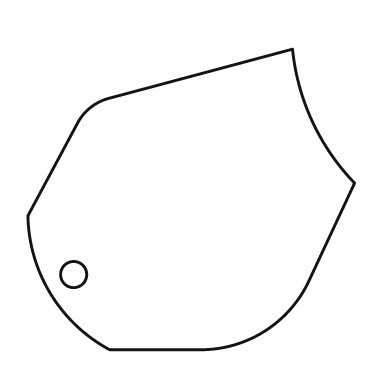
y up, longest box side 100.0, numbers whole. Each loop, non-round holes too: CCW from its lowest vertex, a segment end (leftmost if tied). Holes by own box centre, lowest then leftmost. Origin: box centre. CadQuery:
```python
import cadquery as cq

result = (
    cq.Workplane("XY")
    .moveTo(-25.0, -46.0)
    .lineTo(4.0, -46.0)
    .threePointArc((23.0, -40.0), (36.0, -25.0))
    .lineTo(50.0, 5.0)
    .threePointArc((37.0, 24.0), (31.0, 46.0))
    .lineTo(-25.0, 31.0)
    .threePointArc((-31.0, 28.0), (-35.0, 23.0))
    .lineTo(-50.0, -5.0)
    .threePointArc((-43.0, -29.0), (-25.0, -46.0))
    .close()
    .moveTo(-36.0, -23.0)
    .circle(4.0)
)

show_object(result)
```